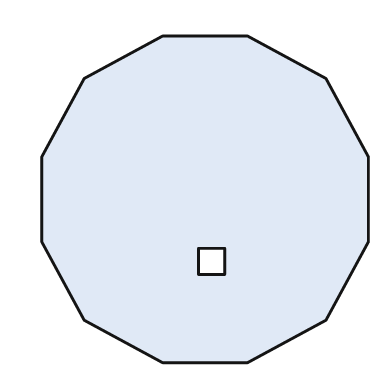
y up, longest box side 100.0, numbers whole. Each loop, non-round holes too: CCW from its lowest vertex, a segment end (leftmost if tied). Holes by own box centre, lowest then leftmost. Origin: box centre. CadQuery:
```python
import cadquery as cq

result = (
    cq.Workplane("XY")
    .moveTo(-13.0, -50.0)
    .lineTo(13.0, -50.0)
    .lineTo(37.0, -37.0)
    .lineTo(50.0, -13.0)
    .lineTo(50.0, 13.0)
    .lineTo(37.0, 37.0)
    .lineTo(13.0, 50.0)
    .lineTo(-13.0, 50.0)
    .lineTo(-37.0, 37.0)
    .lineTo(-50.0, 13.0)
    .lineTo(-50.0, -13.0)
    .lineTo(-37.0, -37.0)
    .close()
    .moveTo(-2.0, -23.0)
    .lineTo(6.0, -23.0)
    .lineTo(6.0, -15.0)
    .lineTo(-2.0, -15.0)
    .close()
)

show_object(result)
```